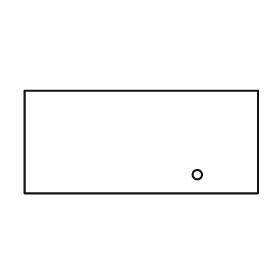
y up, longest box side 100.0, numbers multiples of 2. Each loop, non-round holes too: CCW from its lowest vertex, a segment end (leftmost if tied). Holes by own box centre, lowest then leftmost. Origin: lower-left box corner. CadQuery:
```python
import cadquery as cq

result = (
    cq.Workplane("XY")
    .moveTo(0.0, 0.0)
    .lineTo(100.0, 0.0)
    .lineTo(100.0, 44.0)
    .lineTo(0.0, 44.0)
    .close()
    .moveTo(74.0, 8.0)
    .circle(2.0)
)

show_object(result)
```